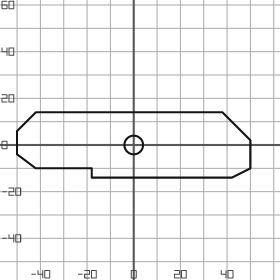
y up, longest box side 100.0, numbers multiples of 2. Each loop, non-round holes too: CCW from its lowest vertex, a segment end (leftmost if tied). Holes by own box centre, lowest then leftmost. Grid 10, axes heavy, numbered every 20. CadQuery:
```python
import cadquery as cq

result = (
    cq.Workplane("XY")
    .moveTo(-18.0, -14.0)
    .lineTo(42.0, -14.0)
    .lineTo(50.0, -10.0)
    .lineTo(50.0, 2.0)
    .lineTo(38.0, 14.0)
    .lineTo(-42.0, 14.0)
    .lineTo(-50.0, 6.0)
    .lineTo(-50.0, -4.0)
    .lineTo(-42.0, -10.0)
    .lineTo(-18.0, -10.0)
    .close()
    .moveTo(0.0, 0.0)
    .circle(4.0)
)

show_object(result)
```